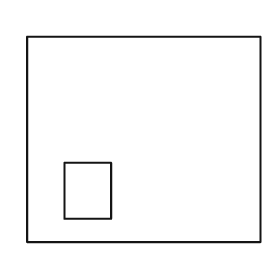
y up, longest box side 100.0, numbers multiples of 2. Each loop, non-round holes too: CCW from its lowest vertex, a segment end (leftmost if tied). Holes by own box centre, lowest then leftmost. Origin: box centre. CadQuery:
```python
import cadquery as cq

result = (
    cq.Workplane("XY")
    .moveTo(-50.0, -44.0)
    .lineTo(50.0, -44.0)
    .lineTo(50.0, 44.0)
    .lineTo(-50.0, 44.0)
    .close()
    .moveTo(-34.0, -34.0)
    .lineTo(-14.0, -34.0)
    .lineTo(-14.0, -10.0)
    .lineTo(-34.0, -10.0)
    .close()
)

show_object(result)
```